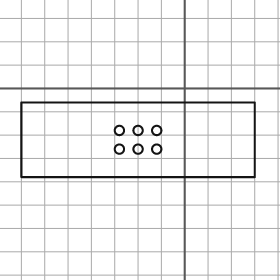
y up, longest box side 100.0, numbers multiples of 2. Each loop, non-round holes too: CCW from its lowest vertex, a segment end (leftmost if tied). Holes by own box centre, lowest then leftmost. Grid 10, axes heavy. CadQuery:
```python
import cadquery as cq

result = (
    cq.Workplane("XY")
    .moveTo(-70.0, -38.0)
    .lineTo(30.0, -38.0)
    .lineTo(30.0, -6.0)
    .lineTo(-70.0, -6.0)
    .close()
    .moveTo(-28.0, -26.0)
    .circle(2.0)
    .moveTo(-20.0, -26.0)
    .circle(2.0)
    .moveTo(-12.0, -26.0)
    .circle(2.0)
    .moveTo(-28.0, -18.0)
    .circle(2.0)
    .moveTo(-20.0, -18.0)
    .circle(2.0)
    .moveTo(-12.0, -18.0)
    .circle(2.0)
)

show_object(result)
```